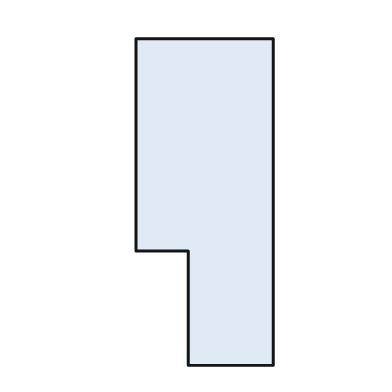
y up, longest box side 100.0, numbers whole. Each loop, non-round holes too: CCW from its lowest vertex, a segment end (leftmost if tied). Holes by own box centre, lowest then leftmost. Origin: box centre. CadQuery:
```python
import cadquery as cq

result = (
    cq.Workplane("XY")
    .moveTo(-5.0, -50.0)
    .lineTo(21.0, -50.0)
    .lineTo(21.0, 50.0)
    .lineTo(-21.0, 50.0)
    .lineTo(-21.0, -15.0)
    .lineTo(-5.0, -15.0)
    .close()
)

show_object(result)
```